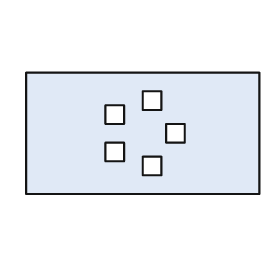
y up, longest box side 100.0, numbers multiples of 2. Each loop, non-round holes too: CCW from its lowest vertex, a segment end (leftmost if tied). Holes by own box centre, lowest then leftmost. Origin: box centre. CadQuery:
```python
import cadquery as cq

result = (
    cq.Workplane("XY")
    .moveTo(-50.0, -26.0)
    .lineTo(50.0, -26.0)
    .lineTo(50.0, 26.0)
    .lineTo(-50.0, 26.0)
    .close()
    .moveTo(0.0, -18.0)
    .lineTo(8.0, -18.0)
    .lineTo(8.0, -10.0)
    .lineTo(0.0, -10.0)
    .close()
    .moveTo(-16.0, -12.0)
    .lineTo(-8.0, -12.0)
    .lineTo(-8.0, -4.0)
    .lineTo(-16.0, -4.0)
    .close()
    .moveTo(10.0, -4.0)
    .lineTo(18.0, -4.0)
    .lineTo(18.0, 4.0)
    .lineTo(10.0, 4.0)
    .close()
    .moveTo(-16.0, 4.0)
    .lineTo(-8.0, 4.0)
    .lineTo(-8.0, 12.0)
    .lineTo(-16.0, 12.0)
    .close()
    .moveTo(0.0, 10.0)
    .lineTo(8.0, 10.0)
    .lineTo(8.0, 18.0)
    .lineTo(0.0, 18.0)
    .close()
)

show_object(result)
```